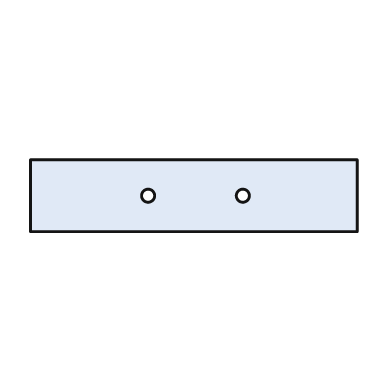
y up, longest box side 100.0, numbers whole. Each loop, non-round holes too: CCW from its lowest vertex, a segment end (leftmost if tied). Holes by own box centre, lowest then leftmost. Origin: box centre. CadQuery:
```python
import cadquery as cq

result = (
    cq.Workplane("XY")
    .moveTo(-50.0, -11.0)
    .lineTo(50.0, -11.0)
    .lineTo(50.0, 11.0)
    .lineTo(-50.0, 11.0)
    .close()
    .moveTo(-14.0, 0.0)
    .circle(2.0)
    .moveTo(15.0, 0.0)
    .circle(2.0)
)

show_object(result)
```